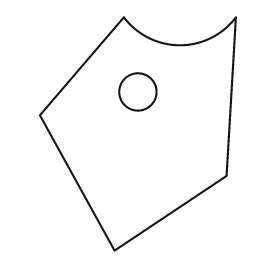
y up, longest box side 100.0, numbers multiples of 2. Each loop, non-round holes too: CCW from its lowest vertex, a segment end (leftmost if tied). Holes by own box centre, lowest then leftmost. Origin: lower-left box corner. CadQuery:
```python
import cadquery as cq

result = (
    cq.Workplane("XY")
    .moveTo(32.0, 0.0)
    .lineTo(80.0, 32.0)
    .lineTo(84.0, 100.0)
    .threePointArc((60.0, 88.0), (36.0, 100.0))
    .lineTo(0.0, 58.0)
    .close()
    .moveTo(42.0, 68.0)
    .circle(8.0)
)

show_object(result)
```